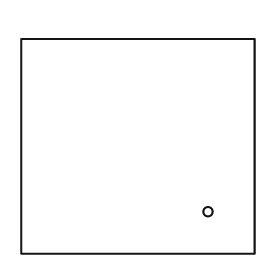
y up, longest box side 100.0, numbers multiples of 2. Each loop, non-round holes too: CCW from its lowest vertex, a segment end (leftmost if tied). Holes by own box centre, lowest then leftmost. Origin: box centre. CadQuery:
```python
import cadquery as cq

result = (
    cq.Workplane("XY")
    .moveTo(-50.0, -46.0)
    .lineTo(50.0, -46.0)
    .lineTo(50.0, 46.0)
    .lineTo(-50.0, 46.0)
    .close()
    .moveTo(30.0, -28.0)
    .circle(2.0)
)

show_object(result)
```